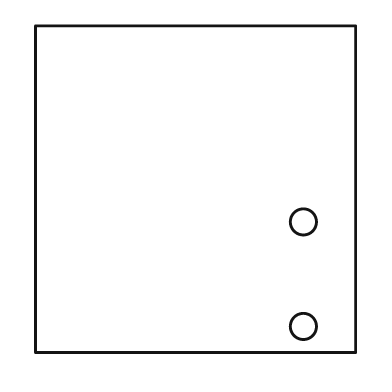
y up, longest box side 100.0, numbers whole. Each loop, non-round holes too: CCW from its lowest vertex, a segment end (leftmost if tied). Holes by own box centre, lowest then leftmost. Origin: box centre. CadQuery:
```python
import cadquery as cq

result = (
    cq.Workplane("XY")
    .moveTo(-49.0, -50.0)
    .lineTo(49.0, -50.0)
    .lineTo(49.0, 50.0)
    .lineTo(-49.0, 50.0)
    .close()
    .moveTo(33.0, -42.0)
    .circle(4.0)
    .moveTo(33.0, -10.0)
    .circle(4.0)
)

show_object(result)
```